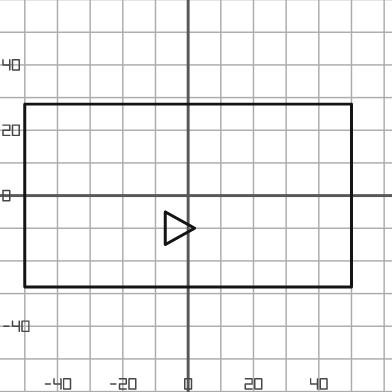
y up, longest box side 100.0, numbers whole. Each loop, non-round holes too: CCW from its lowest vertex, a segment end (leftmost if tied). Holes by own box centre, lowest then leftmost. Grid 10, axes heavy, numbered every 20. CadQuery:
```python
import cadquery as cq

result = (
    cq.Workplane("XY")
    .moveTo(-50.0, -28.0)
    .lineTo(50.0, -28.0)
    .lineTo(50.0, 28.0)
    .lineTo(-50.0, 28.0)
    .close()
    .moveTo(-7.0, -15.0)
    .lineTo(2.0, -10.0)
    .lineTo(-7.0, -5.0)
    .close()
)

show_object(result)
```